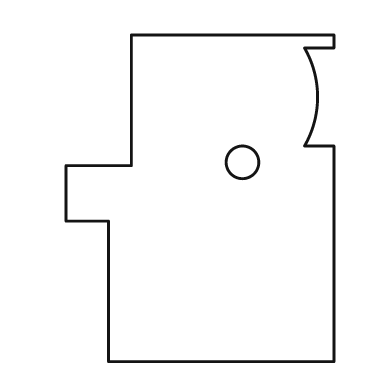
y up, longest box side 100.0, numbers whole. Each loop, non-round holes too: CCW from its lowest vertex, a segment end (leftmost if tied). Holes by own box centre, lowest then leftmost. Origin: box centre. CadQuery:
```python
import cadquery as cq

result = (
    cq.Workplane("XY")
    .moveTo(-28.0, -50.0)
    .lineTo(41.0, -50.0)
    .lineTo(41.0, 16.0)
    .lineTo(32.0, 16.0)
    .threePointArc((36.0, 31.0), (32.0, 46.0))
    .lineTo(41.0, 46.0)
    .lineTo(41.0, 50.0)
    .lineTo(-21.0, 50.0)
    .lineTo(-21.0, 10.0)
    .lineTo(-41.0, 10.0)
    .lineTo(-41.0, -7.0)
    .lineTo(-28.0, -7.0)
    .close()
    .moveTo(13.0, 11.0)
    .circle(5.0)
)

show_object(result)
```